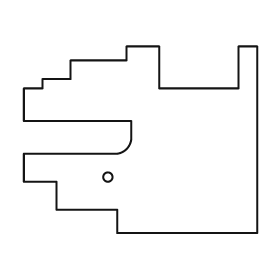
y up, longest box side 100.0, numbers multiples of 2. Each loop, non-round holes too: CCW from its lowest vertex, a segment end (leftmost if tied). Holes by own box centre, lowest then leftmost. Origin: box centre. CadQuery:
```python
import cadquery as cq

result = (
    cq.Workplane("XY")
    .moveTo(-10.0, -40.0)
    .lineTo(50.0, -40.0)
    .lineTo(50.0, 40.0)
    .lineTo(42.0, 40.0)
    .lineTo(42.0, 22.0)
    .lineTo(8.0, 22.0)
    .lineTo(8.0, 40.0)
    .lineTo(-6.0, 40.0)
    .lineTo(-6.0, 34.0)
    .lineTo(-30.0, 34.0)
    .lineTo(-30.0, 26.0)
    .lineTo(-42.0, 26.0)
    .lineTo(-42.0, 22.0)
    .lineTo(-50.0, 22.0)
    .lineTo(-50.0, 8.0)
    .lineTo(-4.0, 8.0)
    .lineTo(-4.0, 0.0)
    .threePointArc((-6.0, -4.0), (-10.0, -6.0))
    .lineTo(-50.0, -6.0)
    .lineTo(-50.0, -18.0)
    .lineTo(-36.0, -18.0)
    .lineTo(-36.0, -30.0)
    .lineTo(-10.0, -30.0)
    .close()
    .moveTo(-14.0, -16.0)
    .circle(2.0)
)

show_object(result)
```